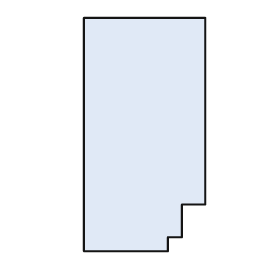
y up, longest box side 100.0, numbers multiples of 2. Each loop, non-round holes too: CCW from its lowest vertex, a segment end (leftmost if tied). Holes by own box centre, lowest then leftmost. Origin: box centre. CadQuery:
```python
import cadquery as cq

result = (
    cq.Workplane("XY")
    .moveTo(-26.0, -50.0)
    .lineTo(10.0, -50.0)
    .lineTo(10.0, -44.0)
    .lineTo(16.0, -44.0)
    .lineTo(16.0, -30.0)
    .lineTo(26.0, -30.0)
    .lineTo(26.0, 50.0)
    .lineTo(-26.0, 50.0)
    .close()
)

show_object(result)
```